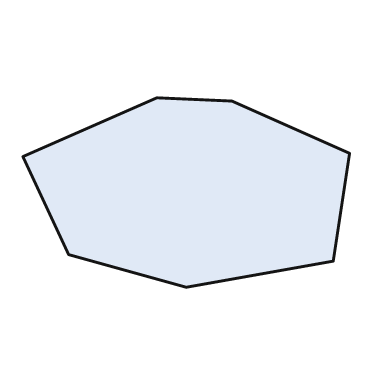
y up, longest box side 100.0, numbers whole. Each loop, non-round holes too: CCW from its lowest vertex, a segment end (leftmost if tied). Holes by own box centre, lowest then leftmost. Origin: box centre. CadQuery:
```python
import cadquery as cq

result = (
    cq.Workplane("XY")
    .moveTo(0.0, -29.0)
    .lineTo(45.0, -21.0)
    .lineTo(50.0, 12.0)
    .lineTo(14.0, 28.0)
    .lineTo(-9.0, 29.0)
    .lineTo(-50.0, 11.0)
    .lineTo(-36.0, -19.0)
    .close()
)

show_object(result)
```